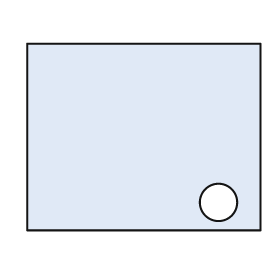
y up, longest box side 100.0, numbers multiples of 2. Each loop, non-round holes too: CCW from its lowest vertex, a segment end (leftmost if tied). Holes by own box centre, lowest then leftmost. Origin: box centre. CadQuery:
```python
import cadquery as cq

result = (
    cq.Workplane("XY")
    .moveTo(-50.0, -40.0)
    .lineTo(50.0, -40.0)
    .lineTo(50.0, 40.0)
    .lineTo(-50.0, 40.0)
    .close()
    .moveTo(32.0, -28.0)
    .circle(8.0)
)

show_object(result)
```